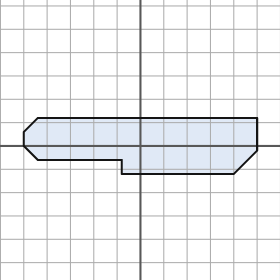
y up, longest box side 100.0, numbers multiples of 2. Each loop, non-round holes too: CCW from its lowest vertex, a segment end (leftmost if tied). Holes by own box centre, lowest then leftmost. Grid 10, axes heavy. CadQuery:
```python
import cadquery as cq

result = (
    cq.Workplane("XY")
    .moveTo(-8.0, -12.0)
    .lineTo(40.0, -12.0)
    .lineTo(50.0, -2.0)
    .lineTo(50.0, 12.0)
    .lineTo(-44.0, 12.0)
    .lineTo(-50.0, 6.0)
    .lineTo(-50.0, 0.0)
    .lineTo(-44.0, -6.0)
    .lineTo(-8.0, -6.0)
    .close()
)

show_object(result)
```